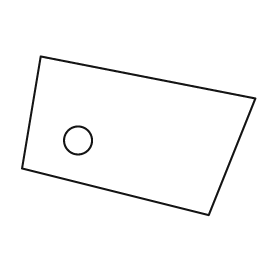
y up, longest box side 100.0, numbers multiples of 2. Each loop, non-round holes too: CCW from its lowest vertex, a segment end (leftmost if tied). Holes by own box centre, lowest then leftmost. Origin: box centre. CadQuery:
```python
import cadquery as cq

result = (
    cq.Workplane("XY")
    .moveTo(30.0, -34.0)
    .lineTo(50.0, 16.0)
    .lineTo(-42.0, 34.0)
    .lineTo(-50.0, -14.0)
    .close()
    .moveTo(-26.0, -2.0)
    .circle(6.0)
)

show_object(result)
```